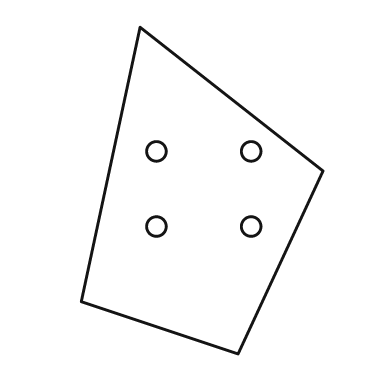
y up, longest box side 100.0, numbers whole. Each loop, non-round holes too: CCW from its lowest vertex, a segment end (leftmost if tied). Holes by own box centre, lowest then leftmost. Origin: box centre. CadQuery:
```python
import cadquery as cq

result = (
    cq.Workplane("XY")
    .moveTo(11.0, -50.0)
    .lineTo(37.0, 6.0)
    .lineTo(-19.0, 50.0)
    .lineTo(-37.0, -34.0)
    .close()
    .moveTo(-14.0, -11.0)
    .circle(3.0)
    .moveTo(15.0, -11.0)
    .circle(3.0)
    .moveTo(-14.0, 12.0)
    .circle(3.0)
    .moveTo(15.0, 12.0)
    .circle(3.0)
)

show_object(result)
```